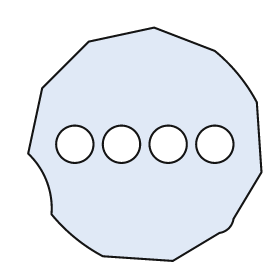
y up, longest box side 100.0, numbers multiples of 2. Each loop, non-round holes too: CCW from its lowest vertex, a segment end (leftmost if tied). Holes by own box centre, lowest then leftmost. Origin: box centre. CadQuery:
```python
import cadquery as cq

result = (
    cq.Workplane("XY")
    .moveTo(12.0, -50.0)
    .lineTo(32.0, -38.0)
    .threePointArc((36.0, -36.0), (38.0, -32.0))
    .lineTo(50.0, -12.0)
    .lineTo(48.0, 18.0)
    .threePointArc((40.0, 30.0), (30.0, 40.0))
    .lineTo(4.0, 50.0)
    .lineTo(-24.0, 44.0)
    .lineTo(-44.0, 24.0)
    .lineTo(-50.0, -4.0)
    .threePointArc((-42.0, -16.0), (-40.0, -30.0))
    .threePointArc((-30.0, -40.0), (-18.0, -48.0))
    .close()
    .moveTo(-30.0, 0.0)
    .circle(8.0)
    .moveTo(-10.0, 0.0)
    .circle(8.0)
    .moveTo(10.0, 0.0)
    .circle(8.0)
    .moveTo(30.0, 0.0)
    .circle(8.0)
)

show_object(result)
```